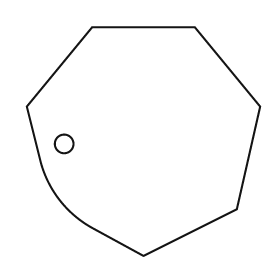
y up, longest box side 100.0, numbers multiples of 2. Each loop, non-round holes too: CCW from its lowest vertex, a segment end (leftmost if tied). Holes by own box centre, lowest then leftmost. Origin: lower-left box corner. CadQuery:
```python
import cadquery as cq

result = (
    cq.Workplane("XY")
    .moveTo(50.0, 0.0)
    .lineTo(90.0, 20.0)
    .lineTo(100.0, 64.0)
    .lineTo(72.0, 98.0)
    .lineTo(28.0, 98.0)
    .lineTo(0.0, 64.0)
    .lineTo(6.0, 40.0)
    .threePointArc((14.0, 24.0), (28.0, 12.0))
    .close()
    .moveTo(16.0, 48.0)
    .circle(4.0)
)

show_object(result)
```